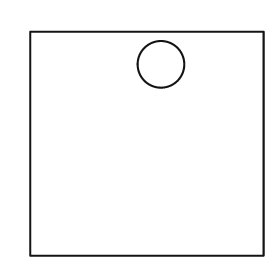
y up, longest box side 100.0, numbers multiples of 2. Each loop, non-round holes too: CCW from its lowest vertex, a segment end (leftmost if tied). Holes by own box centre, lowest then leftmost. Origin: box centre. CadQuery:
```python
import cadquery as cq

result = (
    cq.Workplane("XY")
    .moveTo(-50.0, -48.0)
    .lineTo(50.0, -48.0)
    .lineTo(50.0, 48.0)
    .lineTo(-50.0, 48.0)
    .close()
    .moveTo(6.0, 34.0)
    .circle(10.0)
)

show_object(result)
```